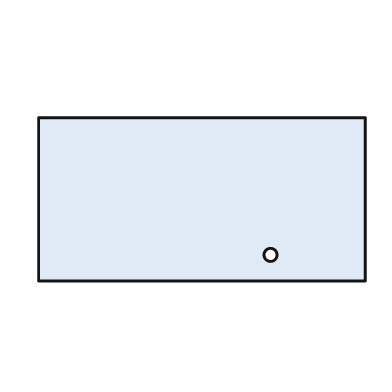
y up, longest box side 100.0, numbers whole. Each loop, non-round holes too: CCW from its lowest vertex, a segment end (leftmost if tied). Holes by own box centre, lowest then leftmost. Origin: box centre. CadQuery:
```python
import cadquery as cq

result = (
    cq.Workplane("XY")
    .moveTo(-50.0, -25.0)
    .lineTo(50.0, -25.0)
    .lineTo(50.0, 25.0)
    .lineTo(-50.0, 25.0)
    .close()
    .moveTo(21.0, -17.0)
    .circle(2.0)
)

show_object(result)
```